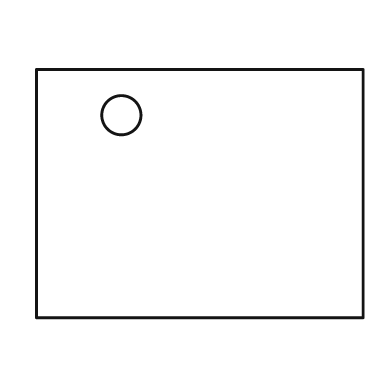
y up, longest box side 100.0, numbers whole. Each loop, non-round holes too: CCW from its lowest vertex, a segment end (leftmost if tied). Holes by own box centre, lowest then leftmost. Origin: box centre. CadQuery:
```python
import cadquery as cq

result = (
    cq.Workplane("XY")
    .moveTo(-50.0, -38.0)
    .lineTo(50.0, -38.0)
    .lineTo(50.0, 38.0)
    .lineTo(-50.0, 38.0)
    .close()
    .moveTo(-24.0, 24.0)
    .circle(6.0)
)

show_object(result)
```